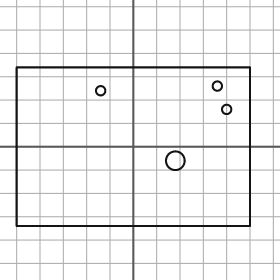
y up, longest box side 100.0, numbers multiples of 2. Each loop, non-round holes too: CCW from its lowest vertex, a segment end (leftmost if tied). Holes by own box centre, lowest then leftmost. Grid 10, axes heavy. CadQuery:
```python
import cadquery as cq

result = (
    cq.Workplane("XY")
    .moveTo(-50.0, -34.0)
    .lineTo(50.0, -34.0)
    .lineTo(50.0, 34.0)
    .lineTo(-50.0, 34.0)
    .close()
    .moveTo(18.0, -6.0)
    .circle(4.0)
    .moveTo(40.0, 16.0)
    .circle(2.0)
    .moveTo(-14.0, 24.0)
    .circle(2.0)
    .moveTo(36.0, 26.0)
    .circle(2.0)
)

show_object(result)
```